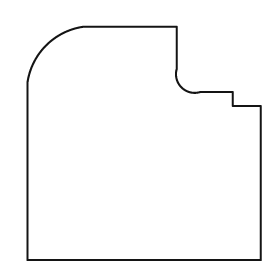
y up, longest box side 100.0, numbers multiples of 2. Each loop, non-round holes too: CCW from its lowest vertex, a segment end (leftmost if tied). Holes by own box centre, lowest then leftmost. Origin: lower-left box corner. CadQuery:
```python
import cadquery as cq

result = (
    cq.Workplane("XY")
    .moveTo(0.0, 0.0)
    .lineTo(100.0, 0.0)
    .lineTo(100.0, 66.0)
    .lineTo(88.0, 66.0)
    .lineTo(88.0, 72.0)
    .lineTo(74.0, 72.0)
    .threePointArc((66.0, 74.0), (64.0, 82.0))
    .lineTo(64.0, 100.0)
    .lineTo(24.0, 100.0)
    .threePointArc((8.0, 92.0), (0.0, 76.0))
    .close()
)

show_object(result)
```